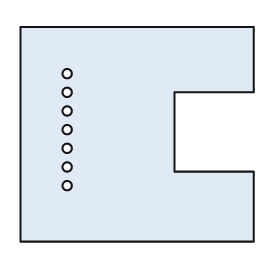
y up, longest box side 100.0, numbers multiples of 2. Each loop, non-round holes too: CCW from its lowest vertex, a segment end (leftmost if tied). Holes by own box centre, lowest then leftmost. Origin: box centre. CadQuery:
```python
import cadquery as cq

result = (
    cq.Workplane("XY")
    .moveTo(-50.0, -46.0)
    .lineTo(50.0, -46.0)
    .lineTo(50.0, -16.0)
    .lineTo(16.0, -16.0)
    .lineTo(16.0, 18.0)
    .lineTo(50.0, 18.0)
    .lineTo(50.0, 46.0)
    .lineTo(-50.0, 46.0)
    .close()
    .moveTo(-30.0, -22.0)
    .circle(2.0)
    .moveTo(-30.0, -14.0)
    .circle(2.0)
    .moveTo(-30.0, -6.0)
    .circle(2.0)
    .moveTo(-30.0, 2.0)
    .circle(2.0)
    .moveTo(-30.0, 10.0)
    .circle(2.0)
    .moveTo(-30.0, 18.0)
    .circle(2.0)
    .moveTo(-30.0, 26.0)
    .circle(2.0)
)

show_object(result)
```